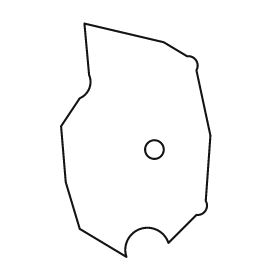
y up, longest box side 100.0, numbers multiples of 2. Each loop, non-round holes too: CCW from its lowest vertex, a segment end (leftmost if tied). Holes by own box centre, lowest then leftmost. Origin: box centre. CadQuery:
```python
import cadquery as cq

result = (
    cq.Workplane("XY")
    .moveTo(-4.0, -50.0)
    .threePointArc((2.0, -38.0), (14.0, -44.0))
    .lineTo(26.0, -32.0)
    .threePointArc((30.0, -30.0), (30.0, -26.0))
    .lineTo(32.0, 2.0)
    .lineTo(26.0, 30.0)
    .threePointArc((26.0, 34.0), (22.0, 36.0))
    .lineTo(12.0, 42.0)
    .lineTo(-22.0, 50.0)
    .lineTo(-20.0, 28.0)
    .threePointArc((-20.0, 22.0), (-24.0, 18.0))
    .lineTo(-32.0, 6.0)
    .lineTo(-30.0, -18.0)
    .lineTo(-24.0, -38.0)
    .close()
    .moveTo(8.0, -4.0)
    .circle(4.0)
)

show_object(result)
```